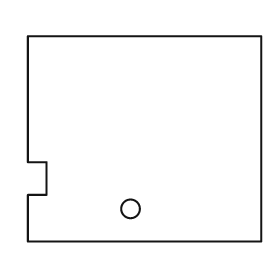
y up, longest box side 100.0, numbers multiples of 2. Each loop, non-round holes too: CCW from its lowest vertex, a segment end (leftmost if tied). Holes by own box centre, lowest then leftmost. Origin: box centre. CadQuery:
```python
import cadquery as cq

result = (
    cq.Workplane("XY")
    .moveTo(-50.0, -44.0)
    .lineTo(50.0, -44.0)
    .lineTo(50.0, 44.0)
    .lineTo(-50.0, 44.0)
    .lineTo(-50.0, -10.0)
    .lineTo(-42.0, -10.0)
    .lineTo(-42.0, -24.0)
    .lineTo(-50.0, -24.0)
    .close()
    .moveTo(-6.0, -30.0)
    .circle(4.0)
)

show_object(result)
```